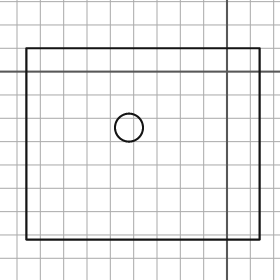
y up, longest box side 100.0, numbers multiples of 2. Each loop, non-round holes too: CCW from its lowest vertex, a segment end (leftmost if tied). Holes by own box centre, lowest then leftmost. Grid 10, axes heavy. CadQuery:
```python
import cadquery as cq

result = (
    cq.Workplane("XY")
    .moveTo(-86.0, -72.0)
    .lineTo(14.0, -72.0)
    .lineTo(14.0, 10.0)
    .lineTo(-86.0, 10.0)
    .close()
    .moveTo(-42.0, -24.0)
    .circle(6.0)
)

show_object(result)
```